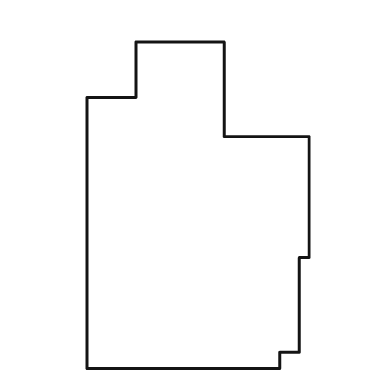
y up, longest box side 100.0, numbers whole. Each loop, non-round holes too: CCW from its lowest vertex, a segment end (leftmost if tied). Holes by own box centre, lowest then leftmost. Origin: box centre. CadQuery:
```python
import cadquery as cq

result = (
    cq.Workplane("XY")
    .moveTo(-34.0, -50.0)
    .lineTo(25.0, -50.0)
    .lineTo(25.0, -45.0)
    .lineTo(31.0, -45.0)
    .lineTo(31.0, -16.0)
    .lineTo(34.0, -16.0)
    .lineTo(34.0, 21.0)
    .lineTo(8.0, 21.0)
    .lineTo(8.0, 50.0)
    .lineTo(-19.0, 50.0)
    .lineTo(-19.0, 33.0)
    .lineTo(-34.0, 33.0)
    .close()
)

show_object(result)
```